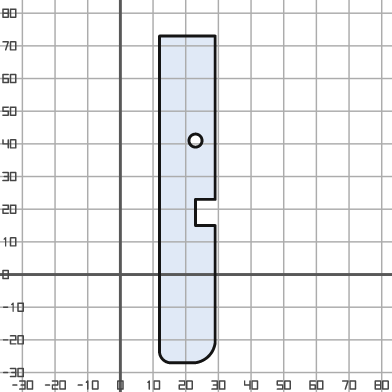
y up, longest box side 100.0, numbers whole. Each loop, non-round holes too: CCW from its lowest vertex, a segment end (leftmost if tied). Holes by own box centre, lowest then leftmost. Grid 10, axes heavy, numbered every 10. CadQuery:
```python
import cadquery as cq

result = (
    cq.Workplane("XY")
    .moveTo(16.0, -27.0)
    .lineTo(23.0, -27.0)
    .threePointArc((27.0, -25.0), (29.0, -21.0))
    .lineTo(29.0, 15.0)
    .lineTo(23.0, 15.0)
    .lineTo(23.0, 23.0)
    .lineTo(29.0, 23.0)
    .lineTo(29.0, 73.0)
    .lineTo(12.0, 73.0)
    .lineTo(12.0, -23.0)
    .threePointArc((13.0, -26.0), (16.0, -27.0))
    .close()
    .moveTo(23.0, 41.0)
    .circle(2.0)
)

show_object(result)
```